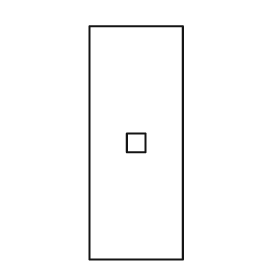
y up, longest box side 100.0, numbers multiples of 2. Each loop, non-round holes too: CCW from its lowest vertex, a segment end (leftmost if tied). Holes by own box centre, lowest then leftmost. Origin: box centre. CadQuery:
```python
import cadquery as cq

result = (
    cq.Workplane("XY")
    .moveTo(-20.0, -50.0)
    .lineTo(20.0, -50.0)
    .lineTo(20.0, 50.0)
    .lineTo(-20.0, 50.0)
    .close()
    .moveTo(-4.0, -4.0)
    .lineTo(4.0, -4.0)
    .lineTo(4.0, 4.0)
    .lineTo(-4.0, 4.0)
    .close()
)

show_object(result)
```